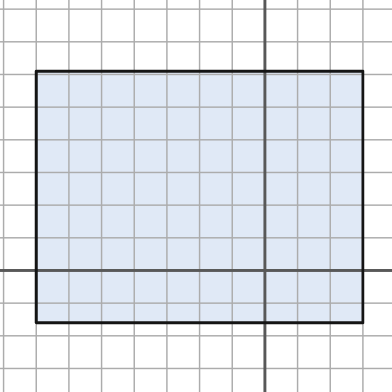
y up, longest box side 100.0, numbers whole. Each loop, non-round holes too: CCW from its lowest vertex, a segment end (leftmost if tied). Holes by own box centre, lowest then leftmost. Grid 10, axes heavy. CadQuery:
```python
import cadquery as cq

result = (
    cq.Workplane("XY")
    .moveTo(-70.0, -16.0)
    .lineTo(30.0, -16.0)
    .lineTo(30.0, 61.0)
    .lineTo(-70.0, 61.0)
    .close()
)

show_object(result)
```